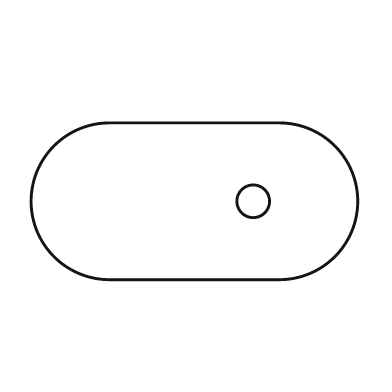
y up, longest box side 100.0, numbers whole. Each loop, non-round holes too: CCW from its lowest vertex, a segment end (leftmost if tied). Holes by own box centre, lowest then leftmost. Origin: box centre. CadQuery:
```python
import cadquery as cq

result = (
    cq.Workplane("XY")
    .moveTo(-26.0, -24.0)
    .lineTo(26.0, -24.0)
    .threePointArc((50.0, 0.0), (26.0, 24.0))
    .lineTo(-26.0, 24.0)
    .threePointArc((-50.0, 0.0), (-26.0, -24.0))
    .close()
    .moveTo(18.0, 0.0)
    .circle(5.0)
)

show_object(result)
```